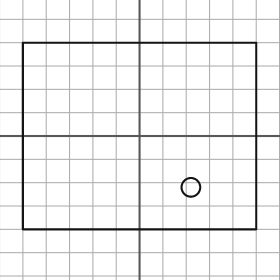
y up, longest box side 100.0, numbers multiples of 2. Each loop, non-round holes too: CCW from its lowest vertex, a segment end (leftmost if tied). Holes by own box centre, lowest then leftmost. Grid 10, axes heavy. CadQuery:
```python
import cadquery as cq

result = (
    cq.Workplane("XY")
    .moveTo(-50.0, -40.0)
    .lineTo(50.0, -40.0)
    .lineTo(50.0, 40.0)
    .lineTo(-50.0, 40.0)
    .close()
    .moveTo(22.0, -22.0)
    .circle(4.0)
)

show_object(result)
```